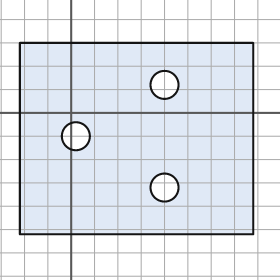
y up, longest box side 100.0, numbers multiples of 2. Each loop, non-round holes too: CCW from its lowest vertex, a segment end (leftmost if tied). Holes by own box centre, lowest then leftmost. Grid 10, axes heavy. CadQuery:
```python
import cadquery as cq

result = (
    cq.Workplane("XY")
    .moveTo(-22.0, -52.0)
    .lineTo(78.0, -52.0)
    .lineTo(78.0, 30.0)
    .lineTo(-22.0, 30.0)
    .close()
    .moveTo(40.0, -32.0)
    .circle(6.0)
    .moveTo(2.0, -10.0)
    .circle(6.0)
    .moveTo(40.0, 12.0)
    .circle(6.0)
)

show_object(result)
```